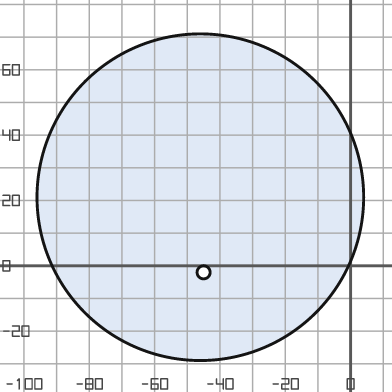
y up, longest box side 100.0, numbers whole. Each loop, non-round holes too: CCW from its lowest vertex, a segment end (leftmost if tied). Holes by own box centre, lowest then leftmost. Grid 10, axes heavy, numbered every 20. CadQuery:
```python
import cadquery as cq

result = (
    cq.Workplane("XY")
    .moveTo(-46.0, 21.0)
    .circle(50.0)
    .moveTo(-45.0, -2.0)
    .circle(2.0)
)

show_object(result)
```